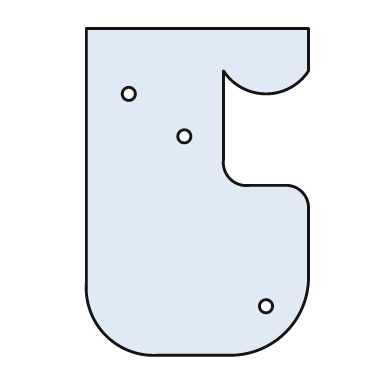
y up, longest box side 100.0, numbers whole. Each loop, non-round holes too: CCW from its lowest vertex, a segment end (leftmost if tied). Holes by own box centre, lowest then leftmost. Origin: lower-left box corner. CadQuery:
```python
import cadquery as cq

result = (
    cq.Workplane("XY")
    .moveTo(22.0, 0.0)
    .lineTo(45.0, 0.0)
    .threePointArc((61.0, 7.0), (68.0, 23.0))
    .lineTo(68.0, 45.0)
    .threePointArc((66.0, 50.0), (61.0, 52.0))
    .lineTo(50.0, 52.0)
    .threePointArc((44.0, 54.0), (42.0, 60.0))
    .lineTo(42.0, 87.0)
    .threePointArc((55.0, 80.0), (68.0, 87.0))
    .lineTo(68.0, 100.0)
    .lineTo(0.0, 100.0)
    .lineTo(0.0, 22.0)
    .threePointArc((6.0, 6.0), (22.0, 0.0))
    .close()
    .moveTo(55.0, 15.0)
    .circle(2.0)
    .moveTo(30.0, 67.0)
    .circle(2.0)
    .moveTo(13.0, 80.0)
    .circle(2.0)
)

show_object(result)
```